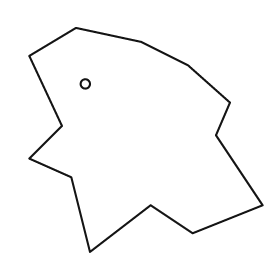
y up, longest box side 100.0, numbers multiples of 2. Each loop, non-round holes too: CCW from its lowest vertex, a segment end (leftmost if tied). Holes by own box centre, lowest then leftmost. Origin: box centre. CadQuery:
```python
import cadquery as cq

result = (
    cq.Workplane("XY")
    .moveTo(-24.0, -48.0)
    .lineTo(2.0, -28.0)
    .lineTo(20.0, -40.0)
    .lineTo(50.0, -28.0)
    .lineTo(30.0, 2.0)
    .lineTo(36.0, 16.0)
    .lineTo(18.0, 32.0)
    .lineTo(-2.0, 42.0)
    .lineTo(-30.0, 48.0)
    .lineTo(-50.0, 36.0)
    .lineTo(-36.0, 6.0)
    .lineTo(-50.0, -8.0)
    .lineTo(-32.0, -16.0)
    .close()
    .moveTo(-26.0, 24.0)
    .circle(2.0)
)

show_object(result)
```